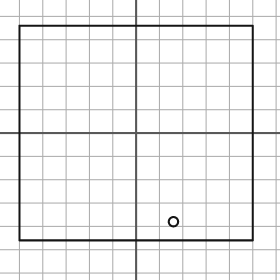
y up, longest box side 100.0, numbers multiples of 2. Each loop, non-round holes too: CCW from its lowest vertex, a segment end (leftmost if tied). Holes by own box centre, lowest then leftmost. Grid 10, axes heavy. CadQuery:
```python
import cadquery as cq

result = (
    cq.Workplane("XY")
    .moveTo(-50.0, -46.0)
    .lineTo(50.0, -46.0)
    .lineTo(50.0, 46.0)
    .lineTo(-50.0, 46.0)
    .close()
    .moveTo(16.0, -38.0)
    .circle(2.0)
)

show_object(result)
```